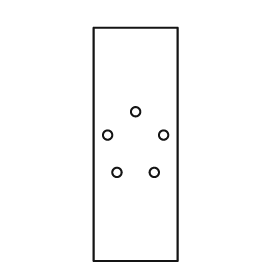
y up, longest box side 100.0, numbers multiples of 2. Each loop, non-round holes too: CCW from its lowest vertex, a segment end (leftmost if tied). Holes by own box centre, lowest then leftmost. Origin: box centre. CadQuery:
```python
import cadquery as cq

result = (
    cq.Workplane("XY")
    .moveTo(-18.0, -50.0)
    .lineTo(18.0, -50.0)
    .lineTo(18.0, 50.0)
    .lineTo(-18.0, 50.0)
    .close()
    .moveTo(-8.0, -12.0)
    .circle(2.0)
    .moveTo(8.0, -12.0)
    .circle(2.0)
    .moveTo(-12.0, 4.0)
    .circle(2.0)
    .moveTo(12.0, 4.0)
    .circle(2.0)
    .moveTo(0.0, 14.0)
    .circle(2.0)
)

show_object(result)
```